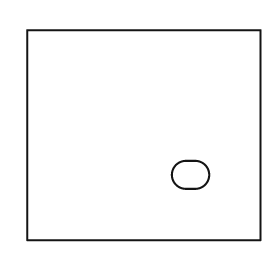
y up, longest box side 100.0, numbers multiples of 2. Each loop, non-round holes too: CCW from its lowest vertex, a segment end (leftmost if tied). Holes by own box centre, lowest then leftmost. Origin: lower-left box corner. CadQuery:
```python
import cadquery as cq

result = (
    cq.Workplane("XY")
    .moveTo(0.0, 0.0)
    .lineTo(100.0, 0.0)
    .lineTo(100.0, 90.0)
    .lineTo(0.0, 90.0)
    .close()
    .moveTo(68.0, 22.0)
    .lineTo(72.0, 22.0)
    .threePointArc((78.0, 28.0), (72.0, 34.0))
    .lineTo(68.0, 34.0)
    .threePointArc((62.0, 28.0), (68.0, 22.0))
    .close()
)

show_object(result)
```